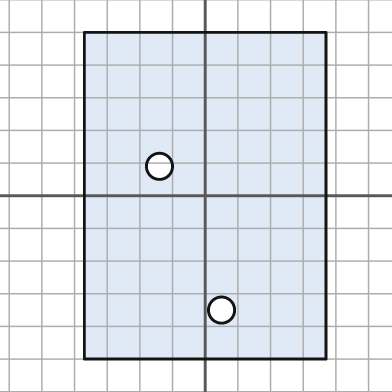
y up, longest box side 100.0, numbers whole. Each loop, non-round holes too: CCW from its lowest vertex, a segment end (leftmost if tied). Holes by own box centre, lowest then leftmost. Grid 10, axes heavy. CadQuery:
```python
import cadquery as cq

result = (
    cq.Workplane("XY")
    .moveTo(-37.0, -50.0)
    .lineTo(37.0, -50.0)
    .lineTo(37.0, 50.0)
    .lineTo(-37.0, 50.0)
    .close()
    .moveTo(5.0, -35.0)
    .circle(4.0)
    .moveTo(-14.0, 9.0)
    .circle(4.0)
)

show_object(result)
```